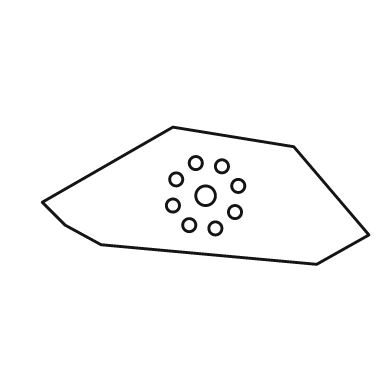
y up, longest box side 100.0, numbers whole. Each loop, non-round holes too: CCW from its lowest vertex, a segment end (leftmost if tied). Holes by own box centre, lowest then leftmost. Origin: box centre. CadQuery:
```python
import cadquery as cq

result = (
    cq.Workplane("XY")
    .moveTo(34.0, -21.0)
    .lineTo(50.0, -12.0)
    .lineTo(27.0, 15.0)
    .lineTo(-10.0, 21.0)
    .lineTo(-50.0, -2.0)
    .lineTo(-43.0, -9.0)
    .lineTo(-32.0, -15.0)
    .close()
    .moveTo(3.0, -10.0)
    .circle(2.0)
    .moveTo(-5.0, -9.0)
    .circle(2.0)
    .moveTo(9.0, -5.0)
    .circle(2.0)
    .moveTo(-10.0, -3.0)
    .circle(2.0)
    .moveTo(0.0, 0.0)
    .circle(3.0)
    .moveTo(10.0, 3.0)
    .circle(2.0)
    .moveTo(-9.0, 5.0)
    .circle(2.0)
    .moveTo(5.0, 9.0)
    .circle(2.0)
    .moveTo(-3.0, 10.0)
    .circle(2.0)
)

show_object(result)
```